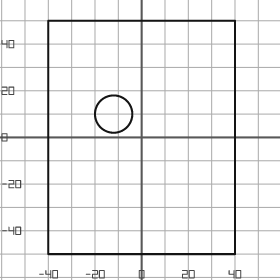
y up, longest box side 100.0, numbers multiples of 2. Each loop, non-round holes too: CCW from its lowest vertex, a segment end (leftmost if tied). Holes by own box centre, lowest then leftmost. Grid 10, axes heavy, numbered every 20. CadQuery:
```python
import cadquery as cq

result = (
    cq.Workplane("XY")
    .moveTo(-40.0, -50.0)
    .lineTo(40.0, -50.0)
    .lineTo(40.0, 50.0)
    .lineTo(-40.0, 50.0)
    .close()
    .moveTo(-12.0, 10.0)
    .circle(8.0)
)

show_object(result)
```